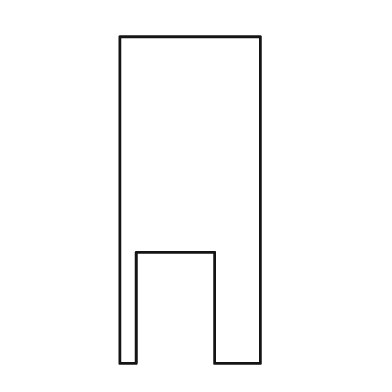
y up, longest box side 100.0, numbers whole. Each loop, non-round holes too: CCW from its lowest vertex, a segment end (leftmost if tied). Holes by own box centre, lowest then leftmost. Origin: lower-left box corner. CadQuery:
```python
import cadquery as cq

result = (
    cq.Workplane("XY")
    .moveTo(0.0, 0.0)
    .lineTo(5.0, 0.0)
    .lineTo(5.0, 34.0)
    .lineTo(29.0, 34.0)
    .lineTo(29.0, 0.0)
    .lineTo(43.0, 0.0)
    .lineTo(43.0, 100.0)
    .lineTo(0.0, 100.0)
    .close()
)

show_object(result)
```